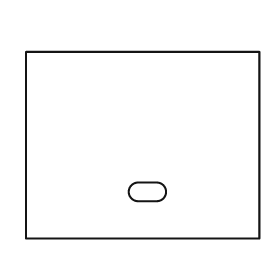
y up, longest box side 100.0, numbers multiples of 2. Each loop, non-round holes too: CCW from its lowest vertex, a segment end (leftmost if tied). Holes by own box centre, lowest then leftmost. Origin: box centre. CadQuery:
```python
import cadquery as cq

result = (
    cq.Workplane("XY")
    .moveTo(-50.0, -40.0)
    .lineTo(50.0, -40.0)
    .lineTo(50.0, 40.0)
    .lineTo(-50.0, 40.0)
    .close()
    .moveTo(-2.0, -24.0)
    .lineTo(6.0, -24.0)
    .threePointArc((10.0, -20.0), (6.0, -16.0))
    .lineTo(-2.0, -16.0)
    .threePointArc((-6.0, -20.0), (-2.0, -24.0))
    .close()
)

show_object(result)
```